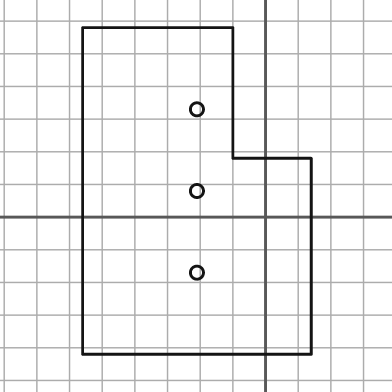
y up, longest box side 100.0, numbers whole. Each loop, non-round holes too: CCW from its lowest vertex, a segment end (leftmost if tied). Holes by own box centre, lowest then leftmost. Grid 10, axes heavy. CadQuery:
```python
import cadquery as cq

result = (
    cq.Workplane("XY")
    .moveTo(-56.0, -42.0)
    .lineTo(14.0, -42.0)
    .lineTo(14.0, 18.0)
    .lineTo(-10.0, 18.0)
    .lineTo(-10.0, 58.0)
    .lineTo(-56.0, 58.0)
    .close()
    .moveTo(-21.0, -17.0)
    .circle(2.0)
    .moveTo(-21.0, 8.0)
    .circle(2.0)
    .moveTo(-21.0, 33.0)
    .circle(2.0)
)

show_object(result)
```